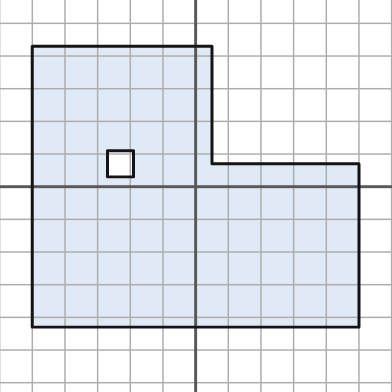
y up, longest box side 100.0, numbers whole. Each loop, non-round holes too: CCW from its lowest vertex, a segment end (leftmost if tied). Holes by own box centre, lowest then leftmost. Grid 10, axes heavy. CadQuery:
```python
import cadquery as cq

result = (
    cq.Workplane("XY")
    .moveTo(-50.0, -43.0)
    .lineTo(50.0, -43.0)
    .lineTo(50.0, 7.0)
    .lineTo(5.0, 7.0)
    .lineTo(5.0, 43.0)
    .lineTo(-50.0, 43.0)
    .close()
    .moveTo(-27.0, 3.0)
    .lineTo(-19.0, 3.0)
    .lineTo(-19.0, 11.0)
    .lineTo(-27.0, 11.0)
    .close()
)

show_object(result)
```